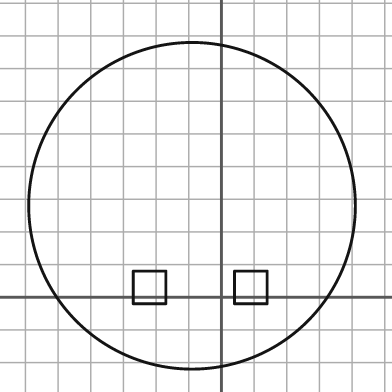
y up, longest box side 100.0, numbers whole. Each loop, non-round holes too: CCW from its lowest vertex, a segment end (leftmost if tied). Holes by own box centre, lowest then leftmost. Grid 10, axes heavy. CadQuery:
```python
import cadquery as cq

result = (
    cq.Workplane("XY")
    .moveTo(-9.0, 28.0)
    .circle(50.0)
    .moveTo(-27.0, -2.0)
    .lineTo(-17.0, -2.0)
    .lineTo(-17.0, 8.0)
    .lineTo(-27.0, 8.0)
    .close()
    .moveTo(4.0, -2.0)
    .lineTo(14.0, -2.0)
    .lineTo(14.0, 8.0)
    .lineTo(4.0, 8.0)
    .close()
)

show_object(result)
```